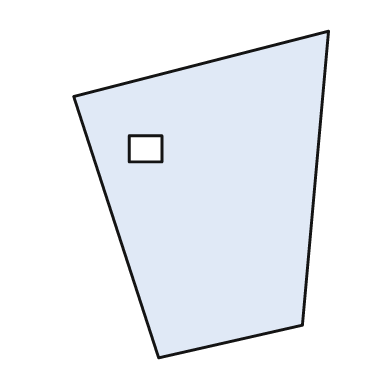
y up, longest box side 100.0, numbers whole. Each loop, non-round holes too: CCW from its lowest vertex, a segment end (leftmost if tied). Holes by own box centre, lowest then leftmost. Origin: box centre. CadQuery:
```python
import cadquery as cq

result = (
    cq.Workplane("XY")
    .moveTo(-13.0, -50.0)
    .lineTo(31.0, -40.0)
    .lineTo(39.0, 50.0)
    .lineTo(-39.0, 30.0)
    .close()
    .moveTo(-22.0, 10.0)
    .lineTo(-12.0, 10.0)
    .lineTo(-12.0, 18.0)
    .lineTo(-22.0, 18.0)
    .close()
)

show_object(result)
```